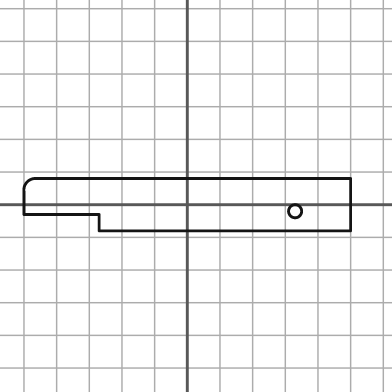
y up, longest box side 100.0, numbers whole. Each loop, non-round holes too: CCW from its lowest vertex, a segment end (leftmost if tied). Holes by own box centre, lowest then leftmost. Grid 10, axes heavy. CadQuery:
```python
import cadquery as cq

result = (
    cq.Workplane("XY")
    .moveTo(-27.0, -8.0)
    .lineTo(50.0, -8.0)
    .lineTo(50.0, 8.0)
    .lineTo(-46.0, 8.0)
    .threePointArc((-49.0, 7.0), (-50.0, 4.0))
    .lineTo(-50.0, -3.0)
    .lineTo(-27.0, -3.0)
    .close()
    .moveTo(33.0, -2.0)
    .circle(2.0)
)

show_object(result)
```